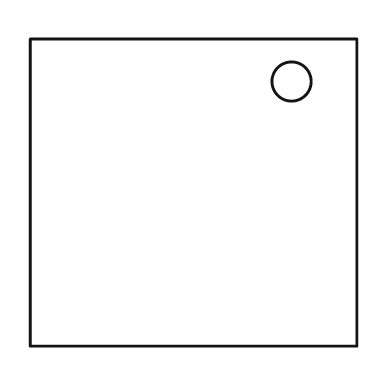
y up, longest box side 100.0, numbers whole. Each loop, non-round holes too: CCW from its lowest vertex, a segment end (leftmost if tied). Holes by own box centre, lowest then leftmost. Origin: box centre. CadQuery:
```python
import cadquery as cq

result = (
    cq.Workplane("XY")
    .moveTo(-50.0, -47.0)
    .lineTo(50.0, -47.0)
    .lineTo(50.0, 47.0)
    .lineTo(-50.0, 47.0)
    .close()
    .moveTo(30.0, 34.0)
    .circle(6.0)
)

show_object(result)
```